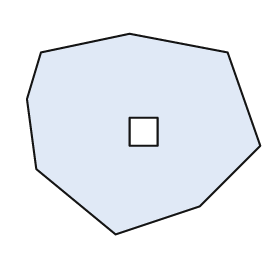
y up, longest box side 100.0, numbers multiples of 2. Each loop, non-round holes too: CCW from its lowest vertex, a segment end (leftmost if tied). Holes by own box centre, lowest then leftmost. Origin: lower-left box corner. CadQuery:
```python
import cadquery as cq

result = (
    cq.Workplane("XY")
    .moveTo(38.0, 0.0)
    .lineTo(74.0, 12.0)
    .lineTo(100.0, 38.0)
    .lineTo(86.0, 78.0)
    .lineTo(44.0, 86.0)
    .lineTo(6.0, 78.0)
    .lineTo(0.0, 58.0)
    .lineTo(4.0, 28.0)
    .close()
    .moveTo(44.0, 38.0)
    .lineTo(56.0, 38.0)
    .lineTo(56.0, 50.0)
    .lineTo(44.0, 50.0)
    .close()
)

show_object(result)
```